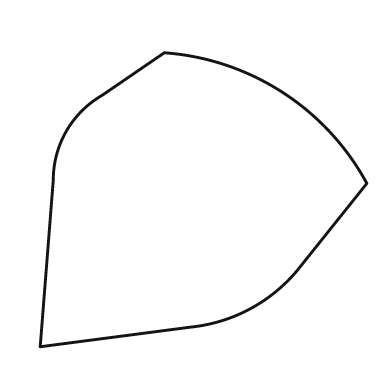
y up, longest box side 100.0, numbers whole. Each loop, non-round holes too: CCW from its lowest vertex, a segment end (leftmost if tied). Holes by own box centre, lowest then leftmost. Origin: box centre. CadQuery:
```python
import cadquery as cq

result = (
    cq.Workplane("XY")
    .moveTo(-50.0, -45.0)
    .lineTo(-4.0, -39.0)
    .threePointArc((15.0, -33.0), (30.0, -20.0))
    .lineTo(50.0, 5.0)
    .threePointArc((24.0, 33.0), (-12.0, 45.0))
    .lineTo(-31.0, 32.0)
    .threePointArc((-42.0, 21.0), (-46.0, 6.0))
    .close()
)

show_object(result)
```